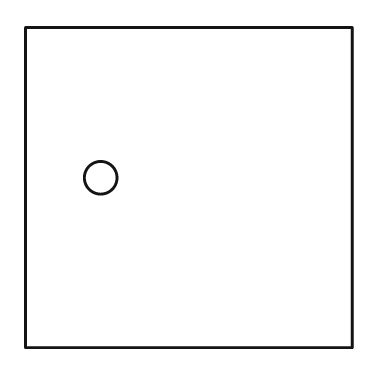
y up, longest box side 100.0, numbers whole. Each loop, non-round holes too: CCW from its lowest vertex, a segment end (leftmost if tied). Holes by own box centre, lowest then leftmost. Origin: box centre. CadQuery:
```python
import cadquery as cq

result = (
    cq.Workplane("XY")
    .moveTo(-50.0, -49.0)
    .lineTo(50.0, -49.0)
    .lineTo(50.0, 49.0)
    .lineTo(-50.0, 49.0)
    .close()
    .moveTo(-27.0, 3.0)
    .circle(5.0)
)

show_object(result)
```